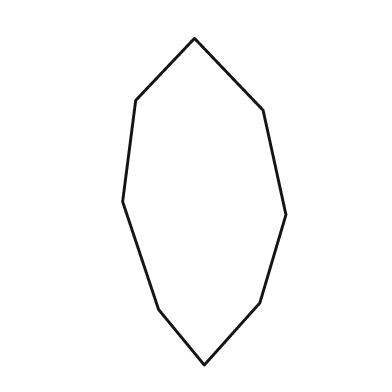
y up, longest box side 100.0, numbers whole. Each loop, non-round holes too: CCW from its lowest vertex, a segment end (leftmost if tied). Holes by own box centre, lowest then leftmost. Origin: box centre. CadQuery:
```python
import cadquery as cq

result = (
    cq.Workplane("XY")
    .moveTo(0.0, -50.0)
    .lineTo(17.0, -31.0)
    .lineTo(25.0, -4.0)
    .lineTo(18.0, 28.0)
    .lineTo(-3.0, 50.0)
    .lineTo(-21.0, 31.0)
    .lineTo(-25.0, 0.0)
    .lineTo(-14.0, -33.0)
    .close()
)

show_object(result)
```